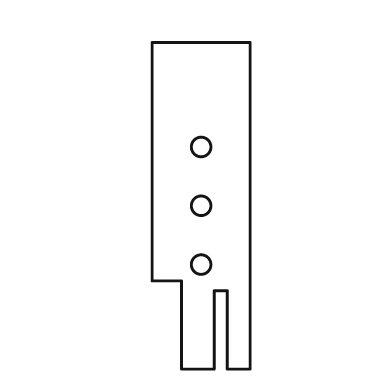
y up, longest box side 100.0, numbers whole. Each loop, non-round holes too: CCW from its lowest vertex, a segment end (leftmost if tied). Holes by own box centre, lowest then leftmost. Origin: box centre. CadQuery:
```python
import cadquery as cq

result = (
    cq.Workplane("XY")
    .moveTo(-6.0, -50.0)
    .lineTo(4.0, -50.0)
    .lineTo(4.0, -26.0)
    .lineTo(8.0, -26.0)
    .lineTo(8.0, -50.0)
    .lineTo(15.0, -50.0)
    .lineTo(15.0, 50.0)
    .lineTo(-15.0, 50.0)
    .lineTo(-15.0, -23.0)
    .lineTo(-6.0, -23.0)
    .close()
    .moveTo(0.0, -18.0)
    .circle(3.0)
    .moveTo(0.0, 0.0)
    .circle(3.0)
    .moveTo(0.0, 18.0)
    .circle(3.0)
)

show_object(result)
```